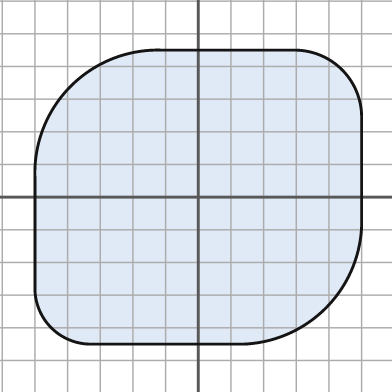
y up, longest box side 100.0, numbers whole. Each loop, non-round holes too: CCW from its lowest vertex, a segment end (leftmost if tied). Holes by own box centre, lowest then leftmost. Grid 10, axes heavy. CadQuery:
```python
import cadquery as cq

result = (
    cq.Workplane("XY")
    .moveTo(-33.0, -45.0)
    .lineTo(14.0, -45.0)
    .threePointArc((39.0, -34.0), (50.0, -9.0))
    .lineTo(50.0, 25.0)
    .threePointArc((44.0, 39.0), (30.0, 45.0))
    .lineTo(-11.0, 45.0)
    .threePointArc((-39.0, 34.0), (-50.0, 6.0))
    .lineTo(-50.0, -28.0)
    .threePointArc((-45.0, -40.0), (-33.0, -45.0))
    .close()
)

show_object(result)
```